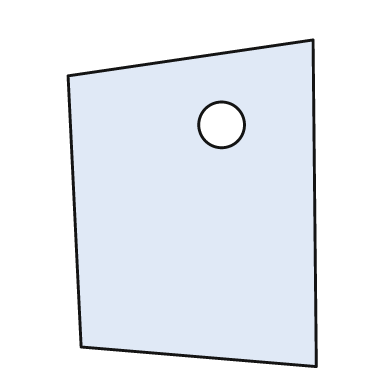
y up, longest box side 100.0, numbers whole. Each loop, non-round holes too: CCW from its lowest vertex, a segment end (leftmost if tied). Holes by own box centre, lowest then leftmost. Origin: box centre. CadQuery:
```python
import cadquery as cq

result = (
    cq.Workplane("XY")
    .moveTo(38.0, -50.0)
    .lineTo(37.0, 50.0)
    .lineTo(-38.0, 39.0)
    .lineTo(-34.0, -44.0)
    .close()
    .moveTo(9.0, 24.0)
    .circle(7.0)
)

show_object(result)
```